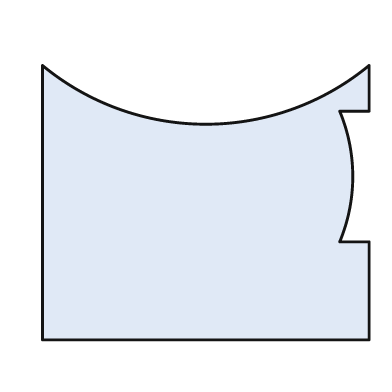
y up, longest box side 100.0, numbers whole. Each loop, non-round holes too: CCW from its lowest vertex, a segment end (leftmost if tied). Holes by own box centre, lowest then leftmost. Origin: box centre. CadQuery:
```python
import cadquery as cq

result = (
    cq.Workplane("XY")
    .moveTo(-50.0, -42.0)
    .lineTo(50.0, -42.0)
    .lineTo(50.0, -12.0)
    .lineTo(41.0, -12.0)
    .threePointArc((45.0, 8.0), (41.0, 28.0))
    .lineTo(50.0, 28.0)
    .lineTo(50.0, 42.0)
    .threePointArc((0.0, 24.0), (-50.0, 42.0))
    .close()
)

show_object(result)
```